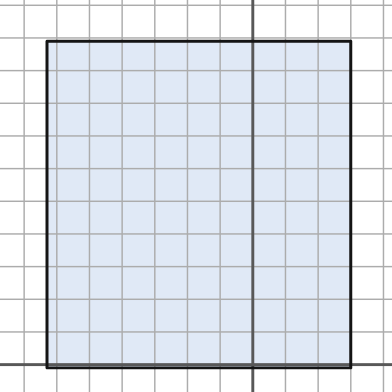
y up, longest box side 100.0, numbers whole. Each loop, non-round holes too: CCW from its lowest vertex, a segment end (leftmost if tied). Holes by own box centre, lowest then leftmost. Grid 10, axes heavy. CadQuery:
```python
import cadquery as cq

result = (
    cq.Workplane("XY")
    .moveTo(-63.0, -1.0)
    .lineTo(30.0, -1.0)
    .lineTo(30.0, 99.0)
    .lineTo(-63.0, 99.0)
    .close()
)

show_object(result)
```